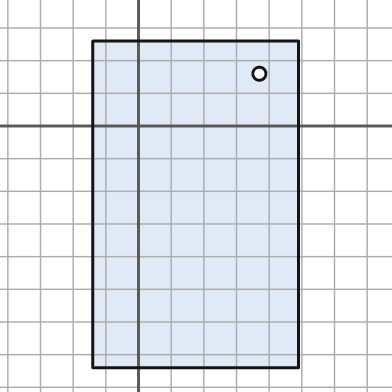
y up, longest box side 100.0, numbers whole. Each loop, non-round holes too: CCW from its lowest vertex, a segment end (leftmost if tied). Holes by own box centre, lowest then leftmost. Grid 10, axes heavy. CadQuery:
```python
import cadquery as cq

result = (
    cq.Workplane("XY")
    .moveTo(-14.0, -74.0)
    .lineTo(49.0, -74.0)
    .lineTo(49.0, 26.0)
    .lineTo(-14.0, 26.0)
    .close()
    .moveTo(37.0, 16.0)
    .circle(2.0)
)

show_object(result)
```